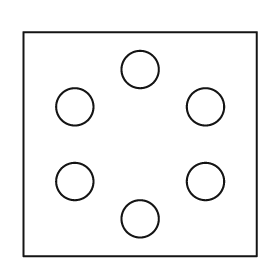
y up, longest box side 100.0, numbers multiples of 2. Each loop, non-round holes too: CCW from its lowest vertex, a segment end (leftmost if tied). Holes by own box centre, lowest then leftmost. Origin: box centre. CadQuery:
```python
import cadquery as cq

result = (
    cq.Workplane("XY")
    .moveTo(-50.0, -48.0)
    .lineTo(50.0, -48.0)
    .lineTo(50.0, 48.0)
    .lineTo(-50.0, 48.0)
    .close()
    .moveTo(0.0, -32.0)
    .circle(8.0)
    .moveTo(-28.0, -16.0)
    .circle(8.0)
    .moveTo(28.0, -16.0)
    .circle(8.0)
    .moveTo(-28.0, 16.0)
    .circle(8.0)
    .moveTo(28.0, 16.0)
    .circle(8.0)
    .moveTo(0.0, 32.0)
    .circle(8.0)
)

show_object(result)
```